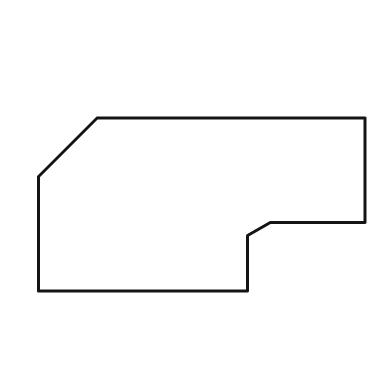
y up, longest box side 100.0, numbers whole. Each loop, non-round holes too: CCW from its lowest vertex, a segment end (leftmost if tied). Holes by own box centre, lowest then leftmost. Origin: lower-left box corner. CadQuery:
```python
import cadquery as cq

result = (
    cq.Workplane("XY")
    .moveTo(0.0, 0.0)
    .lineTo(64.0, 0.0)
    .lineTo(64.0, 17.0)
    .lineTo(71.0, 21.0)
    .lineTo(100.0, 21.0)
    .lineTo(100.0, 53.0)
    .lineTo(18.0, 53.0)
    .lineTo(0.0, 35.0)
    .close()
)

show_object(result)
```